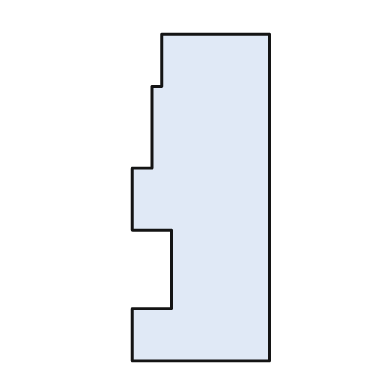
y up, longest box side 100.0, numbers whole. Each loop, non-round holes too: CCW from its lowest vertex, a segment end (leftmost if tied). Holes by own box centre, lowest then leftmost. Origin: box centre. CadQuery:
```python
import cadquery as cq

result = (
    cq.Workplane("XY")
    .moveTo(-21.0, -50.0)
    .lineTo(21.0, -50.0)
    .lineTo(21.0, 50.0)
    .lineTo(-12.0, 50.0)
    .lineTo(-12.0, 34.0)
    .lineTo(-15.0, 34.0)
    .lineTo(-15.0, 9.0)
    .lineTo(-21.0, 9.0)
    .lineTo(-21.0, -10.0)
    .lineTo(-9.0, -10.0)
    .lineTo(-9.0, -34.0)
    .lineTo(-21.0, -34.0)
    .close()
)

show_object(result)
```